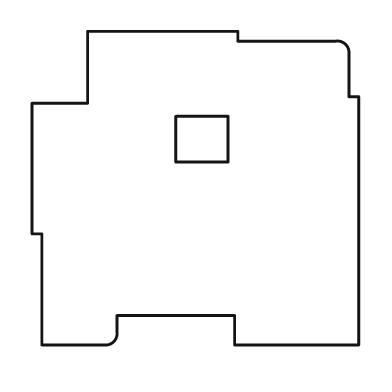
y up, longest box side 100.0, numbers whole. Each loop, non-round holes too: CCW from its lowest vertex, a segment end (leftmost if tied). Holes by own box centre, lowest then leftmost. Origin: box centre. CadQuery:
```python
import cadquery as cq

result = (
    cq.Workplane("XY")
    .moveTo(-47.0, -48.0)
    .lineTo(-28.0, -48.0)
    .threePointArc((-25.0, -47.0), (-24.0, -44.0))
    .lineTo(-24.0, -39.0)
    .lineTo(12.0, -39.0)
    .lineTo(12.0, -48.0)
    .lineTo(50.0, -48.0)
    .lineTo(50.0, 28.0)
    .lineTo(47.0, 28.0)
    .lineTo(47.0, 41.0)
    .threePointArc((46.0, 44.0), (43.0, 45.0))
    .lineTo(13.0, 45.0)
    .lineTo(13.0, 48.0)
    .lineTo(-33.0, 48.0)
    .lineTo(-33.0, 26.0)
    .lineTo(-50.0, 26.0)
    .lineTo(-50.0, -14.0)
    .lineTo(-47.0, -14.0)
    .close()
    .moveTo(-6.0, 8.0)
    .lineTo(10.0, 8.0)
    .lineTo(10.0, 22.0)
    .lineTo(-6.0, 22.0)
    .close()
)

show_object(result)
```